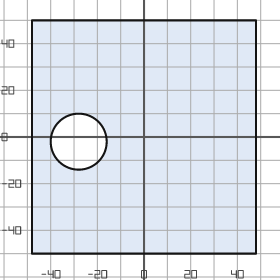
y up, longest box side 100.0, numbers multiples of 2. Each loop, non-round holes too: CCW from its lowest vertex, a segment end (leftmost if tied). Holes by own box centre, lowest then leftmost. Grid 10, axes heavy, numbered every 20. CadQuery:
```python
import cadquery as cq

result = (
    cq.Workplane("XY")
    .moveTo(-48.0, -50.0)
    .lineTo(48.0, -50.0)
    .lineTo(48.0, 50.0)
    .lineTo(-48.0, 50.0)
    .close()
    .moveTo(-28.0, -2.0)
    .circle(12.0)
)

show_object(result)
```